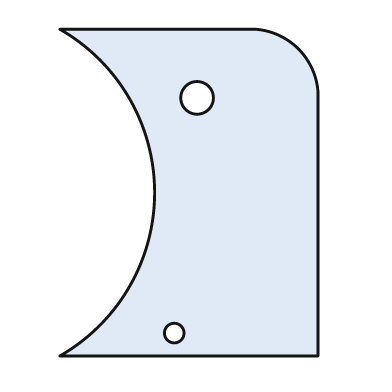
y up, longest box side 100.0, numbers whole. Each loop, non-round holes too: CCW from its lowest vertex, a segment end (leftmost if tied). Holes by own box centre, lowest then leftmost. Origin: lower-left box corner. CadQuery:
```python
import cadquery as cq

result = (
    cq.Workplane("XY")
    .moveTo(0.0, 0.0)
    .lineTo(79.0, 0.0)
    .lineTo(79.0, 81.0)
    .threePointArc((73.0, 94.0), (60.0, 100.0))
    .lineTo(0.0, 100.0)
    .threePointArc((29.0, 50.0), (0.0, 0.0))
    .close()
    .moveTo(35.0, 7.0)
    .circle(3.0)
    .moveTo(42.0, 79.0)
    .circle(5.0)
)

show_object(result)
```